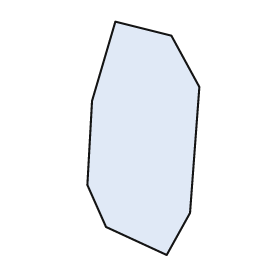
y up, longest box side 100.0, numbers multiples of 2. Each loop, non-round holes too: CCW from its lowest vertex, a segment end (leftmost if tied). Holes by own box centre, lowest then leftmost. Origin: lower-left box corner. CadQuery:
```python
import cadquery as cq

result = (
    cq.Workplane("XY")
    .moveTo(34.0, 0.0)
    .lineTo(44.0, 18.0)
    .lineTo(48.0, 72.0)
    .lineTo(36.0, 94.0)
    .lineTo(12.0, 100.0)
    .lineTo(2.0, 66.0)
    .lineTo(0.0, 30.0)
    .lineTo(8.0, 12.0)
    .close()
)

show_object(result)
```